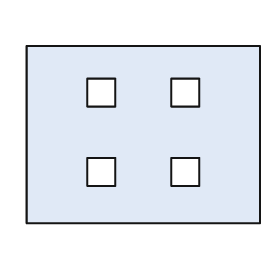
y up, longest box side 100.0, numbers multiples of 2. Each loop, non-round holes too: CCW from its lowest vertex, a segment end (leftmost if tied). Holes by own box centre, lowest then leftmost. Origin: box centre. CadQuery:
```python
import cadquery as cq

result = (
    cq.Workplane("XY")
    .moveTo(-50.0, -38.0)
    .lineTo(50.0, -38.0)
    .lineTo(50.0, 38.0)
    .lineTo(-50.0, 38.0)
    .close()
    .moveTo(-24.0, -22.0)
    .lineTo(-12.0, -22.0)
    .lineTo(-12.0, -10.0)
    .lineTo(-24.0, -10.0)
    .close()
    .moveTo(12.0, -22.0)
    .lineTo(24.0, -22.0)
    .lineTo(24.0, -10.0)
    .lineTo(12.0, -10.0)
    .close()
    .moveTo(-24.0, 12.0)
    .lineTo(-12.0, 12.0)
    .lineTo(-12.0, 24.0)
    .lineTo(-24.0, 24.0)
    .close()
    .moveTo(12.0, 12.0)
    .lineTo(24.0, 12.0)
    .lineTo(24.0, 24.0)
    .lineTo(12.0, 24.0)
    .close()
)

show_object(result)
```